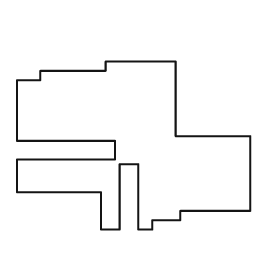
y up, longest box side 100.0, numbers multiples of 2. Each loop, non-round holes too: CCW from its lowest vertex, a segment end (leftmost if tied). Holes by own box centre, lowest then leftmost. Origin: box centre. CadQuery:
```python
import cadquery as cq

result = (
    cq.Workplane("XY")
    .moveTo(-14.0, -36.0)
    .lineTo(-6.0, -36.0)
    .lineTo(-6.0, -8.0)
    .lineTo(2.0, -8.0)
    .lineTo(2.0, -36.0)
    .lineTo(8.0, -36.0)
    .lineTo(8.0, -32.0)
    .lineTo(20.0, -32.0)
    .lineTo(20.0, -28.0)
    .lineTo(50.0, -28.0)
    .lineTo(50.0, 4.0)
    .lineTo(18.0, 4.0)
    .lineTo(18.0, 36.0)
    .lineTo(-12.0, 36.0)
    .lineTo(-12.0, 32.0)
    .lineTo(-40.0, 32.0)
    .lineTo(-40.0, 28.0)
    .lineTo(-50.0, 28.0)
    .lineTo(-50.0, 2.0)
    .lineTo(-8.0, 2.0)
    .lineTo(-8.0, -6.0)
    .lineTo(-50.0, -6.0)
    .lineTo(-50.0, -20.0)
    .lineTo(-14.0, -20.0)
    .close()
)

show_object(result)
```